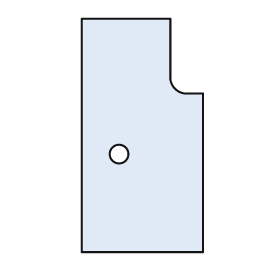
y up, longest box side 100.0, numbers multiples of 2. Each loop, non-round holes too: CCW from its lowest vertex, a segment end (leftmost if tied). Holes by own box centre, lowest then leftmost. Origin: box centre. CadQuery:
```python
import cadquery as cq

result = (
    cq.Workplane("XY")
    .moveTo(-26.0, -50.0)
    .lineTo(26.0, -50.0)
    .lineTo(26.0, 18.0)
    .lineTo(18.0, 18.0)
    .threePointArc((14.0, 20.0), (12.0, 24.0))
    .lineTo(12.0, 50.0)
    .lineTo(-26.0, 50.0)
    .close()
    .moveTo(-10.0, -8.0)
    .circle(4.0)
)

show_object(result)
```